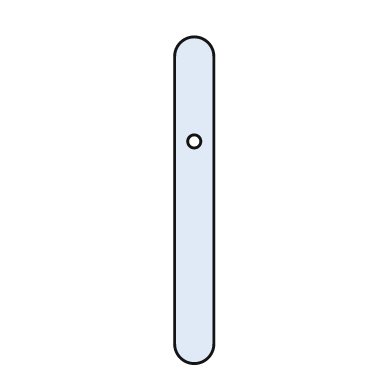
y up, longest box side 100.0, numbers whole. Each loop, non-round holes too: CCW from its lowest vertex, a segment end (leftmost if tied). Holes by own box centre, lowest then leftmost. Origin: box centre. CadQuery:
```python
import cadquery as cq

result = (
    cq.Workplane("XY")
    .moveTo(-6.0, -44.0)
    .threePointArc((0.0, -50.0), (6.0, -44.0))
    .lineTo(6.0, 44.0)
    .threePointArc((0.0, 50.0), (-6.0, 44.0))
    .close()
    .moveTo(0.0, 18.0)
    .circle(2.0)
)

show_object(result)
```